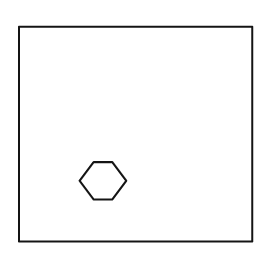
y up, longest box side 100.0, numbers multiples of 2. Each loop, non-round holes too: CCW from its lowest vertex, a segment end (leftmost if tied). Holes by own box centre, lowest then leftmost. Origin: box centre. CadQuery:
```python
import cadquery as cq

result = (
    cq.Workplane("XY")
    .moveTo(-50.0, -46.0)
    .lineTo(50.0, -46.0)
    .lineTo(50.0, 46.0)
    .lineTo(-50.0, 46.0)
    .close()
    .moveTo(-18.0, -28.0)
    .lineTo(-10.0, -28.0)
    .lineTo(-4.0, -20.0)
    .lineTo(-10.0, -12.0)
    .lineTo(-18.0, -12.0)
    .lineTo(-24.0, -20.0)
    .close()
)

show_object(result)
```